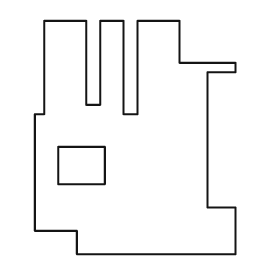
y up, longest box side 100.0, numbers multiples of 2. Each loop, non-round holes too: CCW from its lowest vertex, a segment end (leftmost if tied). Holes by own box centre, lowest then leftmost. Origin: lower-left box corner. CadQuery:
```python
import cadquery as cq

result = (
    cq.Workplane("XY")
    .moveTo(18.0, 0.0)
    .lineTo(86.0, 0.0)
    .lineTo(86.0, 20.0)
    .lineTo(74.0, 20.0)
    .lineTo(74.0, 78.0)
    .lineTo(86.0, 78.0)
    .lineTo(86.0, 82.0)
    .lineTo(62.0, 82.0)
    .lineTo(62.0, 100.0)
    .lineTo(44.0, 100.0)
    .lineTo(44.0, 60.0)
    .lineTo(38.0, 60.0)
    .lineTo(38.0, 100.0)
    .lineTo(28.0, 100.0)
    .lineTo(28.0, 64.0)
    .lineTo(22.0, 64.0)
    .lineTo(22.0, 100.0)
    .lineTo(4.0, 100.0)
    .lineTo(4.0, 60.0)
    .lineTo(0.0, 60.0)
    .lineTo(0.0, 10.0)
    .lineTo(18.0, 10.0)
    .close()
    .moveTo(10.0, 30.0)
    .lineTo(30.0, 30.0)
    .lineTo(30.0, 46.0)
    .lineTo(10.0, 46.0)
    .close()
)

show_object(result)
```